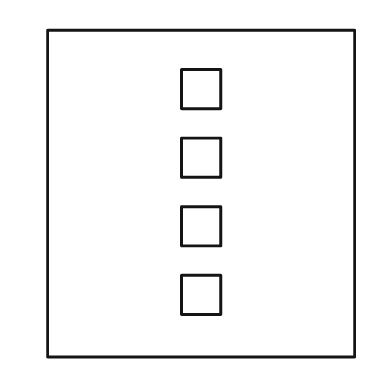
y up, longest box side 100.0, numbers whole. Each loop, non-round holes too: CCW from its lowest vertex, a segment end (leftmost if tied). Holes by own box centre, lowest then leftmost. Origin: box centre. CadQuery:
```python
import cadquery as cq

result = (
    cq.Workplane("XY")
    .moveTo(-47.0, -50.0)
    .lineTo(47.0, -50.0)
    .lineTo(47.0, 50.0)
    .lineTo(-47.0, 50.0)
    .close()
    .moveTo(-6.0, -37.0)
    .lineTo(6.0, -37.0)
    .lineTo(6.0, -25.0)
    .lineTo(-6.0, -25.0)
    .close()
    .moveTo(-6.0, -16.0)
    .lineTo(6.0, -16.0)
    .lineTo(6.0, -4.0)
    .lineTo(-6.0, -4.0)
    .close()
    .moveTo(-6.0, 5.0)
    .lineTo(6.0, 5.0)
    .lineTo(6.0, 17.0)
    .lineTo(-6.0, 17.0)
    .close()
    .moveTo(-6.0, 26.0)
    .lineTo(6.0, 26.0)
    .lineTo(6.0, 38.0)
    .lineTo(-6.0, 38.0)
    .close()
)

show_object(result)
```